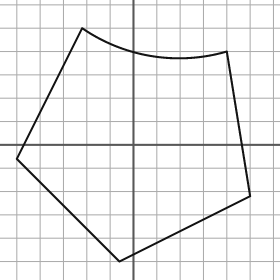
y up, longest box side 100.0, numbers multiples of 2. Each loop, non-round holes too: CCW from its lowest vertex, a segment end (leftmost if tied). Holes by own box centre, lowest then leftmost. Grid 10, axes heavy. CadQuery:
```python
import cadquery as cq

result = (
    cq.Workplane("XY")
    .moveTo(-6.0, -50.0)
    .lineTo(50.0, -22.0)
    .lineTo(40.0, 40.0)
    .threePointArc((8.0, 38.0), (-22.0, 50.0))
    .lineTo(-50.0, -6.0)
    .close()
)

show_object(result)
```